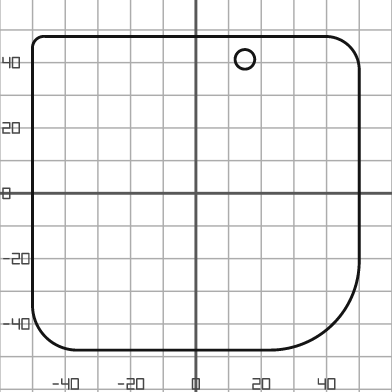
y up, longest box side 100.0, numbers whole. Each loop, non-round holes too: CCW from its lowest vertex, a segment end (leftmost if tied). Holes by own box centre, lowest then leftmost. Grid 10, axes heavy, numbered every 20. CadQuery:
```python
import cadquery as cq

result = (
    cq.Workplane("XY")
    .moveTo(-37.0, -48.0)
    .lineTo(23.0, -48.0)
    .threePointArc((42.0, -40.0), (50.0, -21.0))
    .lineTo(50.0, 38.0)
    .threePointArc((47.0, 45.0), (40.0, 48.0))
    .lineTo(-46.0, 48.0)
    .threePointArc((-49.0, 47.0), (-50.0, 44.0))
    .lineTo(-50.0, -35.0)
    .threePointArc((-46.0, -44.0), (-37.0, -48.0))
    .close()
    .moveTo(15.0, 41.0)
    .circle(3.0)
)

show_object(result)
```